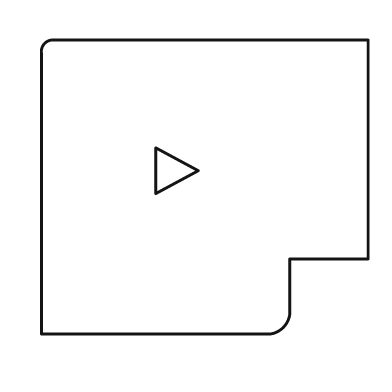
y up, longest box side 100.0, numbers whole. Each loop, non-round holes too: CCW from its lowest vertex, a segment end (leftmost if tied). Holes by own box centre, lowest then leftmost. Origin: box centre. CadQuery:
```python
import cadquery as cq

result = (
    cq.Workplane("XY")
    .moveTo(-50.0, -45.0)
    .lineTo(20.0, -45.0)
    .threePointArc((24.0, -43.0), (26.0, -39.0))
    .lineTo(26.0, -22.0)
    .lineTo(50.0, -22.0)
    .lineTo(50.0, 45.0)
    .lineTo(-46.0, 45.0)
    .threePointArc((-49.0, 44.0), (-50.0, 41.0))
    .close()
    .moveTo(-15.0, -2.0)
    .lineTo(-2.0, 5.0)
    .lineTo(-15.0, 12.0)
    .close()
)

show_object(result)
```